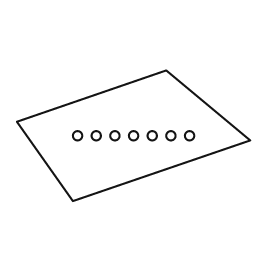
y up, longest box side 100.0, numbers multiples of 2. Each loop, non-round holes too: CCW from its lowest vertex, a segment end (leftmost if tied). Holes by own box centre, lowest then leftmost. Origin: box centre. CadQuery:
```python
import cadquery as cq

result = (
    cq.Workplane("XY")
    .moveTo(-26.0, -28.0)
    .lineTo(50.0, -2.0)
    .lineTo(14.0, 28.0)
    .lineTo(-50.0, 6.0)
    .close()
    .moveTo(-24.0, 0.0)
    .circle(2.0)
    .moveTo(-16.0, 0.0)
    .circle(2.0)
    .moveTo(-8.0, 0.0)
    .circle(2.0)
    .moveTo(0.0, 0.0)
    .circle(2.0)
    .moveTo(8.0, 0.0)
    .circle(2.0)
    .moveTo(16.0, 0.0)
    .circle(2.0)
    .moveTo(24.0, 0.0)
    .circle(2.0)
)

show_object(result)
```